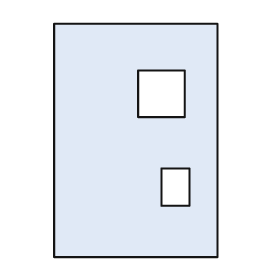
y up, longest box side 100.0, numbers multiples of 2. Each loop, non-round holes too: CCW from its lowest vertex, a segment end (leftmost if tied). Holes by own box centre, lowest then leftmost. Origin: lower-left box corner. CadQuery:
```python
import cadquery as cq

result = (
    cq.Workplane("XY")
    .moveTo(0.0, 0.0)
    .lineTo(70.0, 0.0)
    .lineTo(70.0, 100.0)
    .lineTo(0.0, 100.0)
    .close()
    .moveTo(46.0, 22.0)
    .lineTo(58.0, 22.0)
    .lineTo(58.0, 38.0)
    .lineTo(46.0, 38.0)
    .close()
    .moveTo(36.0, 60.0)
    .lineTo(56.0, 60.0)
    .lineTo(56.0, 80.0)
    .lineTo(36.0, 80.0)
    .close()
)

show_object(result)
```